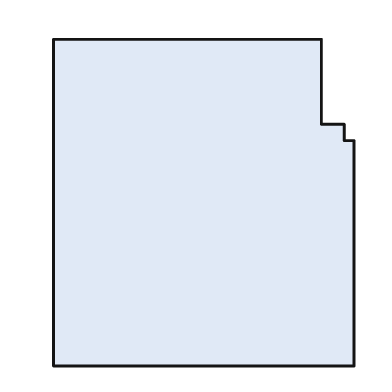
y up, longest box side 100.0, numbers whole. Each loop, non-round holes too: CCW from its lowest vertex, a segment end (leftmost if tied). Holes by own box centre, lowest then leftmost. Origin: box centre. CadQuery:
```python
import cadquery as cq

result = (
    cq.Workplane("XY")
    .moveTo(-46.0, -50.0)
    .lineTo(46.0, -50.0)
    .lineTo(46.0, 19.0)
    .lineTo(43.0, 19.0)
    .lineTo(43.0, 24.0)
    .lineTo(36.0, 24.0)
    .lineTo(36.0, 50.0)
    .lineTo(-46.0, 50.0)
    .close()
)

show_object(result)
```